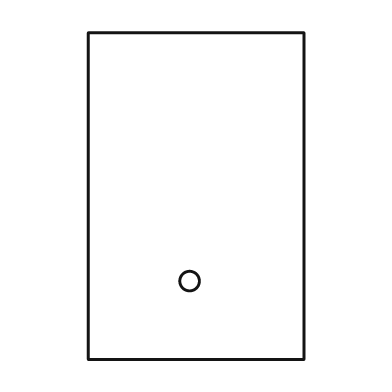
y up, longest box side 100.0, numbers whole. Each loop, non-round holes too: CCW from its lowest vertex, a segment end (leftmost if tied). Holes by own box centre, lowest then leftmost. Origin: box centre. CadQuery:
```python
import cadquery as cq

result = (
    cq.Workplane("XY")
    .moveTo(-33.0, -50.0)
    .lineTo(33.0, -50.0)
    .lineTo(33.0, 50.0)
    .lineTo(-33.0, 50.0)
    .close()
    .moveTo(-2.0, -26.0)
    .circle(3.0)
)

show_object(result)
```